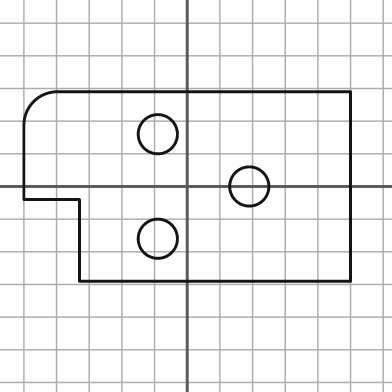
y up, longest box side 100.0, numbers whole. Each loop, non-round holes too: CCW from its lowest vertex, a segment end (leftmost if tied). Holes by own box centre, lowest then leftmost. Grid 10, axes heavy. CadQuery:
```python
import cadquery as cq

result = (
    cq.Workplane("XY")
    .moveTo(-33.0, -29.0)
    .lineTo(50.0, -29.0)
    .lineTo(50.0, 29.0)
    .lineTo(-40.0, 29.0)
    .threePointArc((-47.0, 26.0), (-50.0, 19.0))
    .lineTo(-50.0, -4.0)
    .lineTo(-33.0, -4.0)
    .close()
    .moveTo(-9.0, -16.0)
    .circle(6.0)
    .moveTo(19.0, 0.0)
    .circle(6.0)
    .moveTo(-9.0, 16.0)
    .circle(6.0)
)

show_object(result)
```